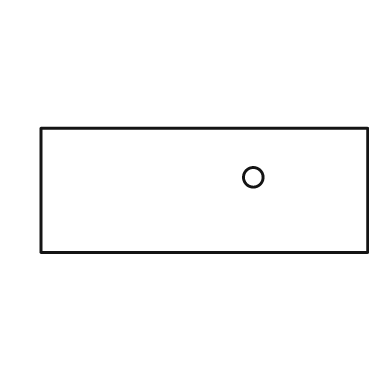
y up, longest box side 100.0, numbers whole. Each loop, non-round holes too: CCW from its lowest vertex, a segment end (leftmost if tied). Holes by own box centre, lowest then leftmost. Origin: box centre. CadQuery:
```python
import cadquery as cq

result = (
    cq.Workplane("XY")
    .moveTo(-50.0, -19.0)
    .lineTo(50.0, -19.0)
    .lineTo(50.0, 19.0)
    .lineTo(-50.0, 19.0)
    .close()
    .moveTo(15.0, 4.0)
    .circle(3.0)
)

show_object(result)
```